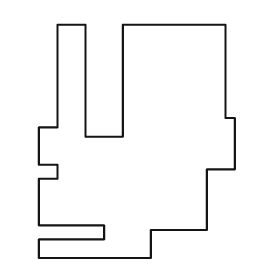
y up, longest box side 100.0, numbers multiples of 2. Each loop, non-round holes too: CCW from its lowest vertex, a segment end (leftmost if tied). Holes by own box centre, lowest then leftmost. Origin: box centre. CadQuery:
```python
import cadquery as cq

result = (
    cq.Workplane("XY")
    .moveTo(-42.0, -50.0)
    .lineTo(6.0, -50.0)
    .lineTo(6.0, -38.0)
    .lineTo(30.0, -38.0)
    .lineTo(30.0, -12.0)
    .lineTo(42.0, -12.0)
    .lineTo(42.0, 10.0)
    .lineTo(38.0, 10.0)
    .lineTo(38.0, 50.0)
    .lineTo(-6.0, 50.0)
    .lineTo(-6.0, 2.0)
    .lineTo(-22.0, 2.0)
    .lineTo(-22.0, 50.0)
    .lineTo(-34.0, 50.0)
    .lineTo(-34.0, 6.0)
    .lineTo(-42.0, 6.0)
    .lineTo(-42.0, -10.0)
    .lineTo(-34.0, -10.0)
    .lineTo(-34.0, -16.0)
    .lineTo(-42.0, -16.0)
    .lineTo(-42.0, -36.0)
    .lineTo(-14.0, -36.0)
    .lineTo(-14.0, -42.0)
    .lineTo(-42.0, -42.0)
    .close()
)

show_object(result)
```